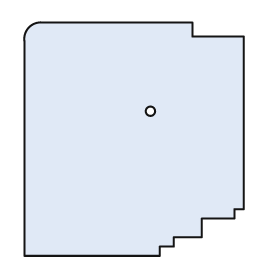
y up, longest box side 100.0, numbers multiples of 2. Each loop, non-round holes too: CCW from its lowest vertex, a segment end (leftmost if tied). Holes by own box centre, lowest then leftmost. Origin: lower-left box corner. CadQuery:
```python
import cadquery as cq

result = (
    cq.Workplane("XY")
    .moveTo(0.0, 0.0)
    .lineTo(58.0, 0.0)
    .lineTo(58.0, 4.0)
    .lineTo(64.0, 4.0)
    .lineTo(64.0, 8.0)
    .lineTo(76.0, 8.0)
    .lineTo(76.0, 16.0)
    .lineTo(90.0, 16.0)
    .lineTo(90.0, 20.0)
    .lineTo(94.0, 20.0)
    .lineTo(94.0, 94.0)
    .lineTo(72.0, 94.0)
    .lineTo(72.0, 100.0)
    .lineTo(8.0, 100.0)
    .threePointArc((2.0, 98.0), (0.0, 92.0))
    .close()
    .moveTo(54.0, 62.0)
    .circle(2.0)
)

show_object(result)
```